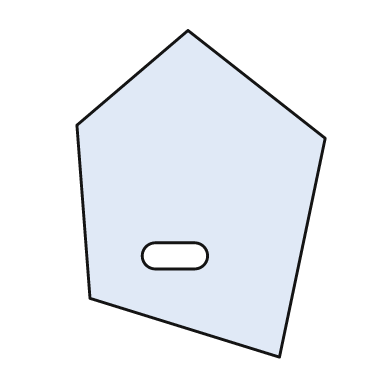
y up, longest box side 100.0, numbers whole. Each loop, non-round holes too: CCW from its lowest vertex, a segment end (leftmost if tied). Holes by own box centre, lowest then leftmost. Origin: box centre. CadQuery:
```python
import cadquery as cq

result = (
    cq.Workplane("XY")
    .moveTo(24.0, -50.0)
    .lineTo(38.0, 17.0)
    .lineTo(-4.0, 50.0)
    .lineTo(-38.0, 21.0)
    .lineTo(-34.0, -32.0)
    .close()
    .moveTo(-14.0, -23.0)
    .lineTo(-2.0, -23.0)
    .threePointArc((2.0, -19.0), (-2.0, -15.0))
    .lineTo(-14.0, -15.0)
    .threePointArc((-18.0, -19.0), (-14.0, -23.0))
    .close()
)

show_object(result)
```